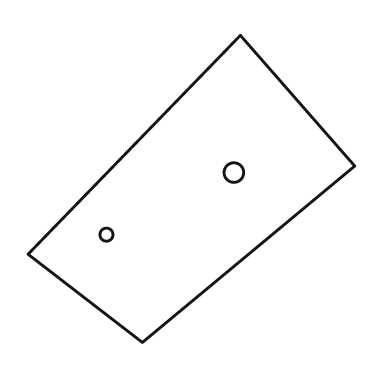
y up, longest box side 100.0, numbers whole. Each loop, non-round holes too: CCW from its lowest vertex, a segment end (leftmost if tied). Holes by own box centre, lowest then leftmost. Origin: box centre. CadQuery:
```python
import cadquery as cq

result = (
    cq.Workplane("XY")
    .moveTo(-15.0, -47.0)
    .lineTo(50.0, 7.0)
    .lineTo(15.0, 47.0)
    .lineTo(-50.0, -20.0)
    .close()
    .moveTo(-26.0, -14.0)
    .circle(2.0)
    .moveTo(13.0, 5.0)
    .circle(3.0)
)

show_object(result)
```